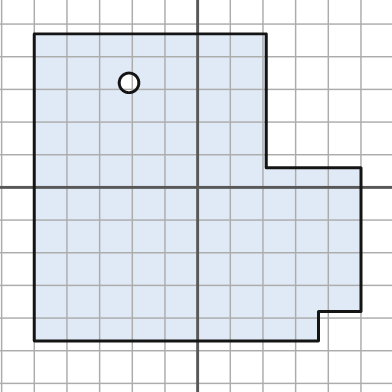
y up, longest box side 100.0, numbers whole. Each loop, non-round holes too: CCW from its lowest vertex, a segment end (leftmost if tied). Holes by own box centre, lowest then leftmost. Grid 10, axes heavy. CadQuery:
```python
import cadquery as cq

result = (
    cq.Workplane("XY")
    .moveTo(-50.0, -47.0)
    .lineTo(37.0, -47.0)
    .lineTo(37.0, -38.0)
    .lineTo(50.0, -38.0)
    .lineTo(50.0, 6.0)
    .lineTo(21.0, 6.0)
    .lineTo(21.0, 47.0)
    .lineTo(-50.0, 47.0)
    .close()
    .moveTo(-21.0, 32.0)
    .circle(3.0)
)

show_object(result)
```